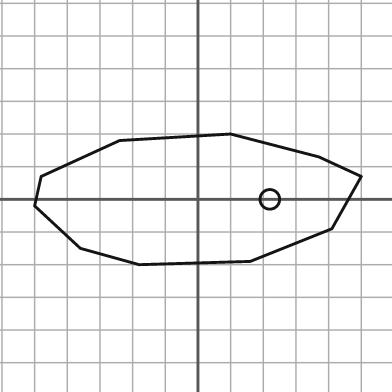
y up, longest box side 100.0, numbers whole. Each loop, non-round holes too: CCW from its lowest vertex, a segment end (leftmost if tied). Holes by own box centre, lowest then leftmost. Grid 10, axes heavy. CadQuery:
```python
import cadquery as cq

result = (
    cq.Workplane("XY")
    .moveTo(-18.0, -20.0)
    .lineTo(16.0, -19.0)
    .lineTo(41.0, -9.0)
    .lineTo(50.0, 7.0)
    .lineTo(37.0, 13.0)
    .lineTo(10.0, 20.0)
    .lineTo(-24.0, 18.0)
    .lineTo(-48.0, 7.0)
    .lineTo(-50.0, -2.0)
    .lineTo(-36.0, -15.0)
    .close()
    .moveTo(22.0, 0.0)
    .circle(3.0)
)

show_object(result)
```